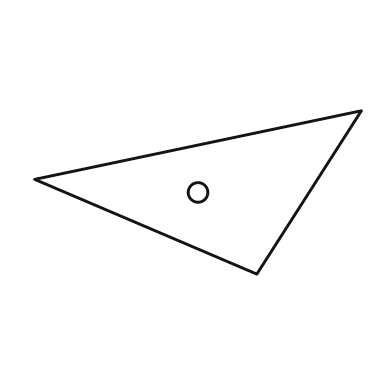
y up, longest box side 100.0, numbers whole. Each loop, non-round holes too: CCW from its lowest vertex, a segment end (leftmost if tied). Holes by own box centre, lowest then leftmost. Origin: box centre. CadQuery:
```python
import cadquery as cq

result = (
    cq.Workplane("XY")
    .moveTo(18.0, -25.0)
    .lineTo(50.0, 25.0)
    .lineTo(-50.0, 4.0)
    .close()
    .moveTo(0.0, 0.0)
    .circle(3.0)
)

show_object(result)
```